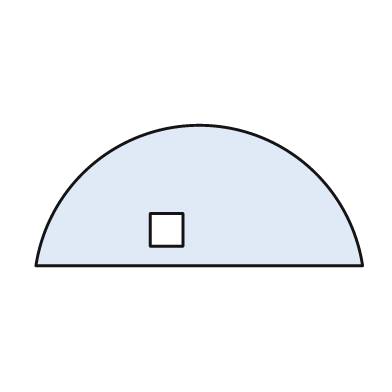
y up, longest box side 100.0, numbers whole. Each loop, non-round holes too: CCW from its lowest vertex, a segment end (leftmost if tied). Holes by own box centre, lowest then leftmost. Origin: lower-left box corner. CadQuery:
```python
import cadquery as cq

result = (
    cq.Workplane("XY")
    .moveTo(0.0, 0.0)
    .lineTo(100.0, 0.0)
    .threePointArc((50.0, 43.0), (0.0, 0.0))
    .close()
    .moveTo(35.0, 6.0)
    .lineTo(45.0, 6.0)
    .lineTo(45.0, 16.0)
    .lineTo(35.0, 16.0)
    .close()
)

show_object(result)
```